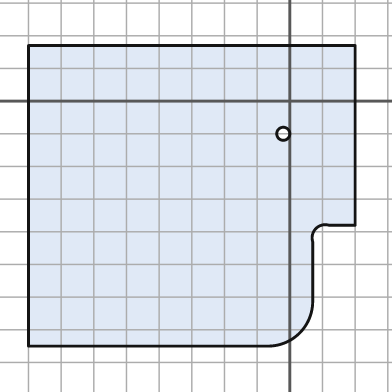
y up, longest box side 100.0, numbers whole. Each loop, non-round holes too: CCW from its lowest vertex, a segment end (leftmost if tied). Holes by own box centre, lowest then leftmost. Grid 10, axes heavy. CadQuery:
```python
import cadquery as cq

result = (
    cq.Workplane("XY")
    .moveTo(-80.0, -75.0)
    .lineTo(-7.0, -75.0)
    .threePointArc((3.0, -71.0), (7.0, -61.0))
    .lineTo(7.0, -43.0)
    .threePointArc((8.0, -39.0), (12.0, -38.0))
    .lineTo(20.0, -38.0)
    .lineTo(20.0, 17.0)
    .lineTo(-80.0, 17.0)
    .close()
    .moveTo(-2.0, -10.0)
    .circle(2.0)
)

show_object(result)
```